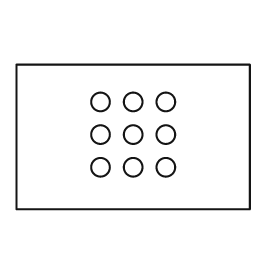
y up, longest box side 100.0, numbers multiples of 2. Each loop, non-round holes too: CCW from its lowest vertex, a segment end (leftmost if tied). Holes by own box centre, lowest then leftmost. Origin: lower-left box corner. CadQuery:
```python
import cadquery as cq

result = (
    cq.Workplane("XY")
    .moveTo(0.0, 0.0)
    .lineTo(100.0, 0.0)
    .lineTo(100.0, 62.0)
    .lineTo(0.0, 62.0)
    .close()
    .moveTo(36.0, 18.0)
    .circle(4.0)
    .moveTo(50.0, 18.0)
    .circle(4.0)
    .moveTo(64.0, 18.0)
    .circle(4.0)
    .moveTo(36.0, 32.0)
    .circle(4.0)
    .moveTo(50.0, 32.0)
    .circle(4.0)
    .moveTo(64.0, 32.0)
    .circle(4.0)
    .moveTo(36.0, 46.0)
    .circle(4.0)
    .moveTo(50.0, 46.0)
    .circle(4.0)
    .moveTo(64.0, 46.0)
    .circle(4.0)
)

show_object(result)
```